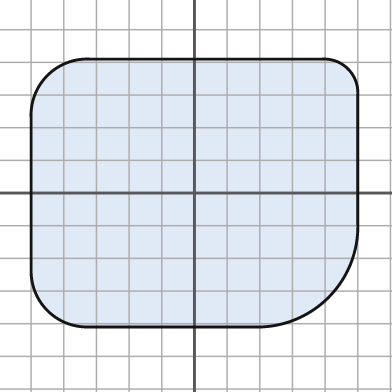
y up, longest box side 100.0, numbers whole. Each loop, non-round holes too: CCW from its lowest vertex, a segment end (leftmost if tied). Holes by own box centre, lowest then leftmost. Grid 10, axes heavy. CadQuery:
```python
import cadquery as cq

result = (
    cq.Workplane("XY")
    .moveTo(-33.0, -41.0)
    .lineTo(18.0, -41.0)
    .threePointArc((41.0, -32.0), (50.0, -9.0))
    .lineTo(50.0, 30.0)
    .threePointArc((47.0, 38.0), (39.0, 41.0))
    .lineTo(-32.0, 41.0)
    .threePointArc((-45.0, 36.0), (-50.0, 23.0))
    .lineTo(-50.0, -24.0)
    .threePointArc((-45.0, -36.0), (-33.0, -41.0))
    .close()
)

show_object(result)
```